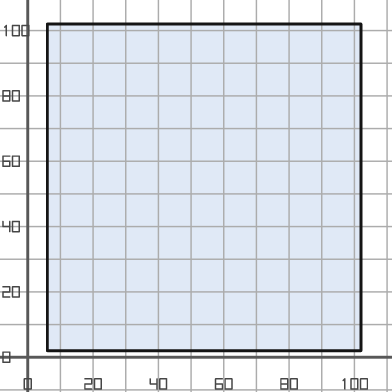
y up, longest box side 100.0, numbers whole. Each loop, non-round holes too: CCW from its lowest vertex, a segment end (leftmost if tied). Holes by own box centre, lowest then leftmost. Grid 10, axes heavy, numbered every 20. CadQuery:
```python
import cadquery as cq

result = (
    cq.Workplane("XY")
    .moveTo(6.0, 2.0)
    .lineTo(102.0, 2.0)
    .lineTo(102.0, 102.0)
    .lineTo(6.0, 102.0)
    .close()
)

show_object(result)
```